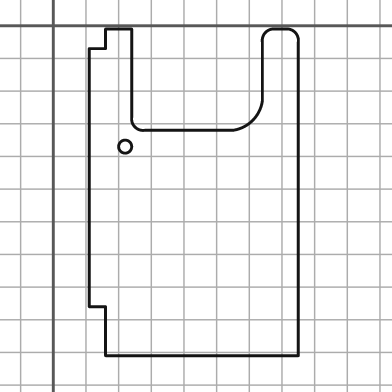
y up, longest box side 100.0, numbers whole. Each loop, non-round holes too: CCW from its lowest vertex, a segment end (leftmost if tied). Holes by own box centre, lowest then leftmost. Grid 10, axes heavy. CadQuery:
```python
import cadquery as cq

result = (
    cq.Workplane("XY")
    .moveTo(16.0, -101.0)
    .lineTo(75.0, -101.0)
    .lineTo(75.0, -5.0)
    .threePointArc((74.0, -2.0), (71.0, -1.0))
    .lineTo(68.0, -1.0)
    .threePointArc((65.0, -2.0), (64.0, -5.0))
    .lineTo(64.0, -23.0)
    .threePointArc((61.0, -29.0), (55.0, -32.0))
    .lineTo(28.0, -32.0)
    .threePointArc((25.0, -31.0), (24.0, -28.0))
    .lineTo(24.0, -1.0)
    .lineTo(16.0, -1.0)
    .lineTo(16.0, -7.0)
    .lineTo(11.0, -7.0)
    .lineTo(11.0, -86.0)
    .lineTo(16.0, -86.0)
    .close()
    .moveTo(22.0, -37.0)
    .circle(2.0)
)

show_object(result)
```